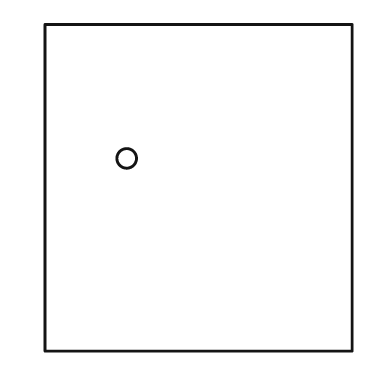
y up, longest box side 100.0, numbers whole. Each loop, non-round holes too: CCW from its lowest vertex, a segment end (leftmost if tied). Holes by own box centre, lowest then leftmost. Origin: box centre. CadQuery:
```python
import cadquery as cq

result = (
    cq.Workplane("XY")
    .moveTo(-47.0, -50.0)
    .lineTo(47.0, -50.0)
    .lineTo(47.0, 50.0)
    .lineTo(-47.0, 50.0)
    .close()
    .moveTo(-22.0, 9.0)
    .circle(3.0)
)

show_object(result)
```